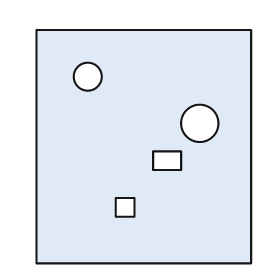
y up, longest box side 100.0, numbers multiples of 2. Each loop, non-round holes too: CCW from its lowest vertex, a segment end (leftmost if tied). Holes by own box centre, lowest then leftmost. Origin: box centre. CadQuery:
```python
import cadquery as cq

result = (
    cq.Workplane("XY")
    .moveTo(-46.0, -50.0)
    .lineTo(46.0, -50.0)
    .lineTo(46.0, 50.0)
    .lineTo(-46.0, 50.0)
    .close()
    .moveTo(-12.0, -30.0)
    .lineTo(-4.0, -30.0)
    .lineTo(-4.0, -22.0)
    .lineTo(-12.0, -22.0)
    .close()
    .moveTo(4.0, -10.0)
    .lineTo(16.0, -10.0)
    .lineTo(16.0, -2.0)
    .lineTo(4.0, -2.0)
    .close()
    .moveTo(24.0, 10.0)
    .circle(8.0)
    .moveTo(-24.0, 30.0)
    .circle(6.0)
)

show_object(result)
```